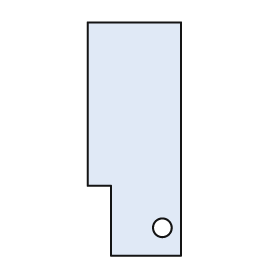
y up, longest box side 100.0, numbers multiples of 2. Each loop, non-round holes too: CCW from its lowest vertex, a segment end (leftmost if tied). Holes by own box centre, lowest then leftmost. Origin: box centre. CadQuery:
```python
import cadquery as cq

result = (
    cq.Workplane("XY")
    .moveTo(-10.0, -50.0)
    .lineTo(20.0, -50.0)
    .lineTo(20.0, 50.0)
    .lineTo(-20.0, 50.0)
    .lineTo(-20.0, -20.0)
    .lineTo(-10.0, -20.0)
    .close()
    .moveTo(12.0, -38.0)
    .circle(4.0)
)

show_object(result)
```